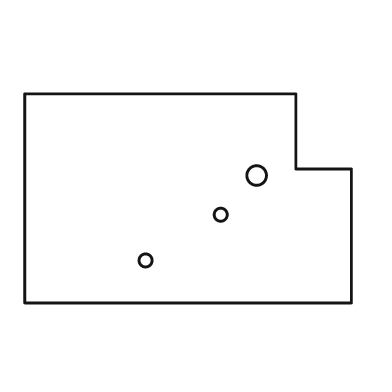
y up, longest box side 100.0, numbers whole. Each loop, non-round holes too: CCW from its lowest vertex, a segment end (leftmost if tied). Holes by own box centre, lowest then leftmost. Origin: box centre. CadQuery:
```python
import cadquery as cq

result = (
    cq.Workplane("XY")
    .moveTo(-50.0, -32.0)
    .lineTo(50.0, -32.0)
    .lineTo(50.0, 9.0)
    .lineTo(33.0, 9.0)
    .lineTo(33.0, 32.0)
    .lineTo(-50.0, 32.0)
    .close()
    .moveTo(-13.0, -19.0)
    .circle(2.0)
    .moveTo(10.0, -5.0)
    .circle(2.0)
    .moveTo(21.0, 7.0)
    .circle(3.0)
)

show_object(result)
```